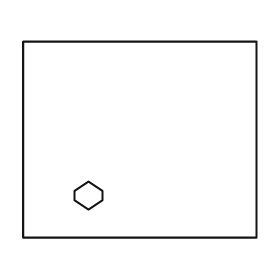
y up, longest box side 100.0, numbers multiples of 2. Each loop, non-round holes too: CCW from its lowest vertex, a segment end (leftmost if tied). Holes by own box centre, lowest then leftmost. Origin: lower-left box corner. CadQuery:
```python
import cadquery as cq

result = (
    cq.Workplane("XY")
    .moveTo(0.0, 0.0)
    .lineTo(100.0, 0.0)
    .lineTo(100.0, 84.0)
    .lineTo(0.0, 84.0)
    .close()
    .moveTo(28.0, 12.0)
    .lineTo(34.0, 16.0)
    .lineTo(34.0, 20.0)
    .lineTo(28.0, 24.0)
    .lineTo(22.0, 20.0)
    .lineTo(22.0, 16.0)
    .close()
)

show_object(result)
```